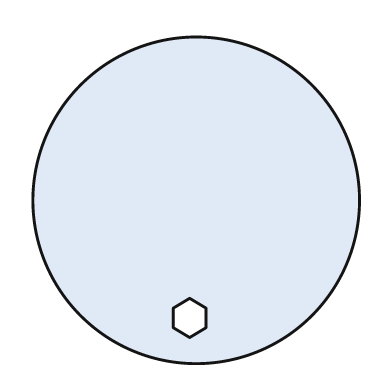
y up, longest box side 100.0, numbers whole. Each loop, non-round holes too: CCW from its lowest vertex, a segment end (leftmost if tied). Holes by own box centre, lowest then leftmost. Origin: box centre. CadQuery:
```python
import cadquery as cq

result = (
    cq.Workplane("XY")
    .moveTo(0.0, 0.0)
    .circle(50.0)
    .moveTo(-2.0, -42.0)
    .lineTo(3.0, -39.0)
    .lineTo(3.0, -33.0)
    .lineTo(-2.0, -30.0)
    .lineTo(-7.0, -33.0)
    .lineTo(-7.0, -39.0)
    .close()
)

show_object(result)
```